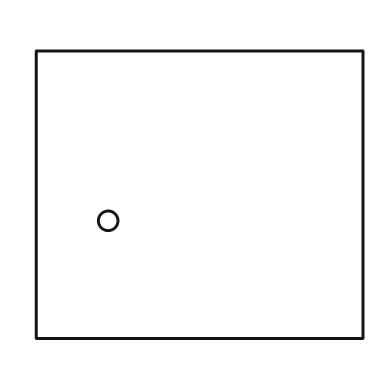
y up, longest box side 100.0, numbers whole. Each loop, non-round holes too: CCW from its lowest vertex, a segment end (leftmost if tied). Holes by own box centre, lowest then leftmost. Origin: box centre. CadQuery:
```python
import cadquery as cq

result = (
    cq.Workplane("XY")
    .moveTo(-50.0, -44.0)
    .lineTo(50.0, -44.0)
    .lineTo(50.0, 44.0)
    .lineTo(-50.0, 44.0)
    .close()
    .moveTo(-28.0, -8.0)
    .circle(3.0)
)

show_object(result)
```